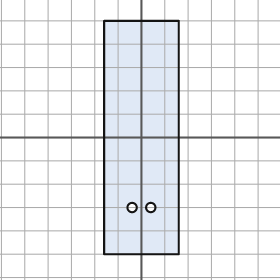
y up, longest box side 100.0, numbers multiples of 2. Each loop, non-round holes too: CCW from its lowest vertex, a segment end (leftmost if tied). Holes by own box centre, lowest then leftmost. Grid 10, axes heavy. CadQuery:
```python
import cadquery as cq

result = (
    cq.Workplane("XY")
    .moveTo(-16.0, -50.0)
    .lineTo(16.0, -50.0)
    .lineTo(16.0, 50.0)
    .lineTo(-16.0, 50.0)
    .close()
    .moveTo(-4.0, -30.0)
    .circle(2.0)
    .moveTo(4.0, -30.0)
    .circle(2.0)
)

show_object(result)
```